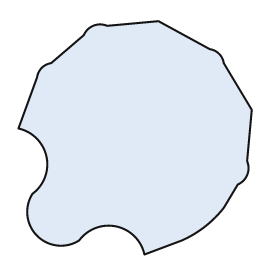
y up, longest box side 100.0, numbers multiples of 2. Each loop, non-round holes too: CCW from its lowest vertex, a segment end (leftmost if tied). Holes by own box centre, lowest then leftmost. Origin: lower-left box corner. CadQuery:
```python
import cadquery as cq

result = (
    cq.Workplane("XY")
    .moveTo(54.0, 0.0)
    .lineTo(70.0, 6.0)
    .threePointArc((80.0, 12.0), (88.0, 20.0))
    .lineTo(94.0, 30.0)
    .threePointArc((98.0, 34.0), (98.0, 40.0))
    .lineTo(100.0, 62.0)
    .lineTo(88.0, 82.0)
    .threePointArc((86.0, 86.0), (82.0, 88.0))
    .lineTo(60.0, 100.0)
    .lineTo(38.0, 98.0)
    .threePointArc((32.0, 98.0), (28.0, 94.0))
    .lineTo(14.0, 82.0)
    .threePointArc((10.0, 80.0), (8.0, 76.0))
    .lineTo(0.0, 54.0)
    .threePointArc((12.0, 42.0), (6.0, 26.0))
    .threePointArc((8.0, 8.0), (26.0, 6.0))
    .threePointArc((42.0, 12.0), (54.0, 0.0))
    .close()
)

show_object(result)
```